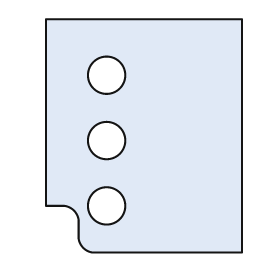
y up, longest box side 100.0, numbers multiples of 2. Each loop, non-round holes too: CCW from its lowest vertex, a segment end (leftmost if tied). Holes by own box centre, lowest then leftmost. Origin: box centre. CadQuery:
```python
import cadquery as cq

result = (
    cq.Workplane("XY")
    .moveTo(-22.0, -50.0)
    .lineTo(42.0, -50.0)
    .lineTo(42.0, 50.0)
    .lineTo(-42.0, 50.0)
    .lineTo(-42.0, -30.0)
    .lineTo(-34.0, -30.0)
    .threePointArc((-30.0, -32.0), (-28.0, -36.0))
    .lineTo(-28.0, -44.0)
    .threePointArc((-26.0, -48.0), (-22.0, -50.0))
    .close()
    .moveTo(-16.0, -30.0)
    .circle(8.0)
    .moveTo(-16.0, -2.0)
    .circle(8.0)
    .moveTo(-16.0, 26.0)
    .circle(8.0)
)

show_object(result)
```